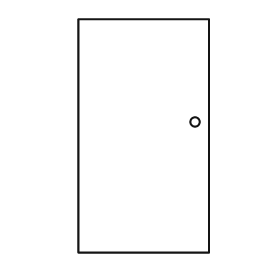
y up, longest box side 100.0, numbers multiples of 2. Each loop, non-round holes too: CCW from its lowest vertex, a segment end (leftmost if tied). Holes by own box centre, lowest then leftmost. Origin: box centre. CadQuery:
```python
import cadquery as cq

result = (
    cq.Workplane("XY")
    .moveTo(-28.0, -50.0)
    .lineTo(28.0, -50.0)
    .lineTo(28.0, 50.0)
    .lineTo(-28.0, 50.0)
    .close()
    .moveTo(22.0, 6.0)
    .circle(2.0)
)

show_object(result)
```